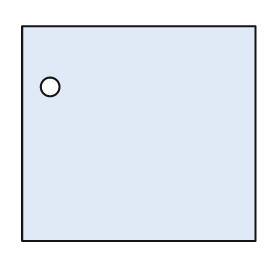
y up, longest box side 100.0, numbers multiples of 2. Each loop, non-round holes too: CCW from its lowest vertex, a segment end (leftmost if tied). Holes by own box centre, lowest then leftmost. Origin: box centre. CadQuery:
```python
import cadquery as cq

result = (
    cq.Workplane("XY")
    .moveTo(-50.0, -46.0)
    .lineTo(50.0, -46.0)
    .lineTo(50.0, 46.0)
    .lineTo(-50.0, 46.0)
    .close()
    .moveTo(-38.0, 20.0)
    .circle(4.0)
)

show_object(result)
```